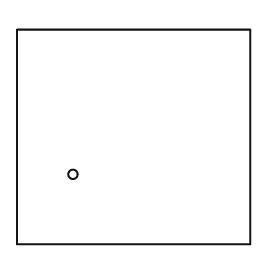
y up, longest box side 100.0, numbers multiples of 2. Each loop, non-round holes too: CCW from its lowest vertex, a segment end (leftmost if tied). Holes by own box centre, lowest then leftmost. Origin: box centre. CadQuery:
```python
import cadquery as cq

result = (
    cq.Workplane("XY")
    .moveTo(-50.0, -46.0)
    .lineTo(50.0, -46.0)
    .lineTo(50.0, 46.0)
    .lineTo(-50.0, 46.0)
    .close()
    .moveTo(-26.0, -16.0)
    .circle(2.0)
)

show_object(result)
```